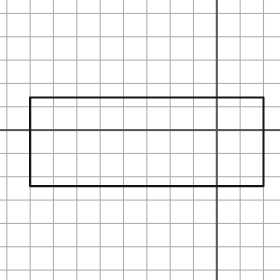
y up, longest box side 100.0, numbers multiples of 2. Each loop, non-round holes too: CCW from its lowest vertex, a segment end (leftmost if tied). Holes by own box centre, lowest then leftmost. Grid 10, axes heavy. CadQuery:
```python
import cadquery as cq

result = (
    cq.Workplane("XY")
    .moveTo(-80.0, -24.0)
    .lineTo(20.0, -24.0)
    .lineTo(20.0, 14.0)
    .lineTo(-80.0, 14.0)
    .close()
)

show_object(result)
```